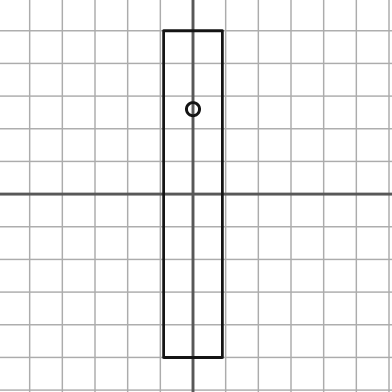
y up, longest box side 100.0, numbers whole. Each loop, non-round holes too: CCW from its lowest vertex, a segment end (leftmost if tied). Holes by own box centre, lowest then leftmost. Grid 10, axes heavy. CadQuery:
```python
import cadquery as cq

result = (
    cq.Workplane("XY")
    .moveTo(-9.0, -50.0)
    .lineTo(9.0, -50.0)
    .lineTo(9.0, 50.0)
    .lineTo(-9.0, 50.0)
    .close()
    .moveTo(0.0, 26.0)
    .circle(2.0)
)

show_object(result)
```